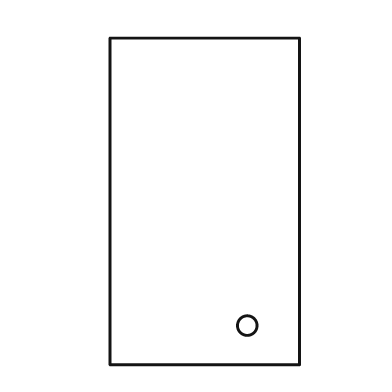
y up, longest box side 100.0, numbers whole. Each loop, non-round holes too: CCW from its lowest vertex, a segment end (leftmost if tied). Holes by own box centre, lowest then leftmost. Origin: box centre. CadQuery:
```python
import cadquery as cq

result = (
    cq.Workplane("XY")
    .moveTo(-29.0, -50.0)
    .lineTo(29.0, -50.0)
    .lineTo(29.0, 50.0)
    .lineTo(-29.0, 50.0)
    .close()
    .moveTo(13.0, -38.0)
    .circle(3.0)
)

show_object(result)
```